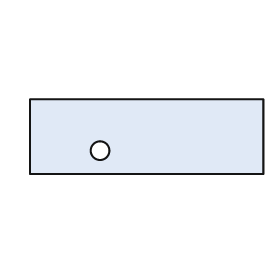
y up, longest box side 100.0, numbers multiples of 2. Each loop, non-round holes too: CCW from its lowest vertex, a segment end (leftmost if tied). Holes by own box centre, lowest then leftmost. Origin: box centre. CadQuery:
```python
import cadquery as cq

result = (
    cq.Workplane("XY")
    .moveTo(-50.0, -16.0)
    .lineTo(50.0, -16.0)
    .lineTo(50.0, 16.0)
    .lineTo(-50.0, 16.0)
    .close()
    .moveTo(-20.0, -6.0)
    .circle(4.0)
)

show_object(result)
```